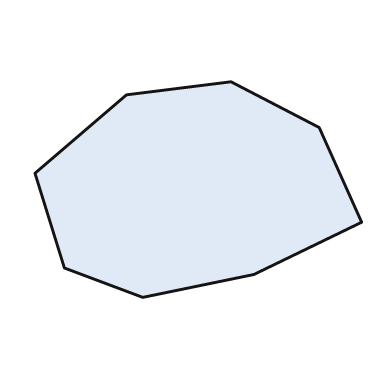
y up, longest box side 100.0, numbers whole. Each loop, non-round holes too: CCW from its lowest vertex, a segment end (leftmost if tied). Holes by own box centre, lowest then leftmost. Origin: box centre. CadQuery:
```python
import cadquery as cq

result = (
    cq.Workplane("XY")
    .moveTo(-17.0, -33.0)
    .lineTo(17.0, -26.0)
    .lineTo(50.0, -10.0)
    .lineTo(37.0, 19.0)
    .lineTo(10.0, 33.0)
    .lineTo(-22.0, 29.0)
    .lineTo(-50.0, 5.0)
    .lineTo(-41.0, -24.0)
    .close()
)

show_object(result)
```